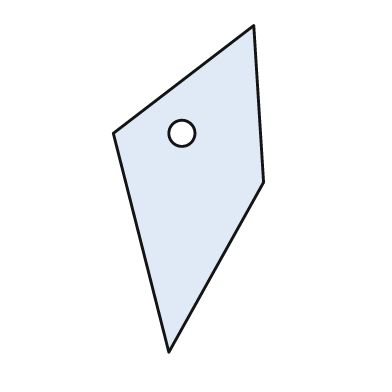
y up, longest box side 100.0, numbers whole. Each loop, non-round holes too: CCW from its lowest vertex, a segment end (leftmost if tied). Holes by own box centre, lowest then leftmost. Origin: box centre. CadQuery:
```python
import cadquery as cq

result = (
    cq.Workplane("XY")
    .moveTo(-6.0, -50.0)
    .lineTo(23.0, 2.0)
    .lineTo(20.0, 50.0)
    .lineTo(-23.0, 17.0)
    .close()
    .moveTo(-2.0, 17.0)
    .circle(4.0)
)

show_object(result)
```